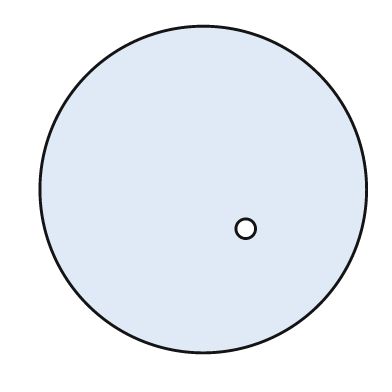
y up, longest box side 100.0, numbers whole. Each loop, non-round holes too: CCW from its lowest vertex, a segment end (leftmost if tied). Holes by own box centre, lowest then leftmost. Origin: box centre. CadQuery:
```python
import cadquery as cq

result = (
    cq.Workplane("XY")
    .moveTo(0.0, 0.0)
    .circle(50.0)
    .moveTo(13.0, -12.0)
    .circle(3.0)
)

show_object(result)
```